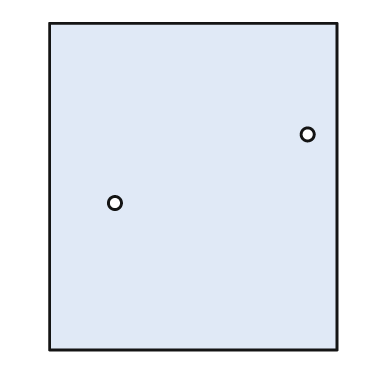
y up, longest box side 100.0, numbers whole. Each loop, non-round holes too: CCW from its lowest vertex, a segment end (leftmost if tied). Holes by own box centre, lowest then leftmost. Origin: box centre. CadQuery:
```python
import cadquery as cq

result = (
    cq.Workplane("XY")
    .moveTo(-44.0, -50.0)
    .lineTo(44.0, -50.0)
    .lineTo(44.0, 50.0)
    .lineTo(-44.0, 50.0)
    .close()
    .moveTo(-24.0, -5.0)
    .circle(2.0)
    .moveTo(35.0, 16.0)
    .circle(2.0)
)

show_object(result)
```